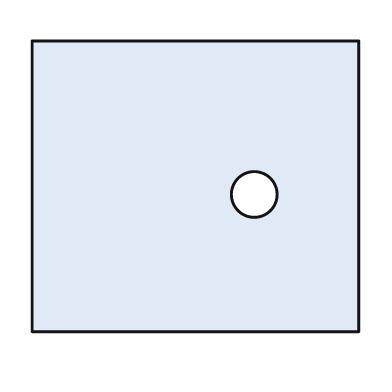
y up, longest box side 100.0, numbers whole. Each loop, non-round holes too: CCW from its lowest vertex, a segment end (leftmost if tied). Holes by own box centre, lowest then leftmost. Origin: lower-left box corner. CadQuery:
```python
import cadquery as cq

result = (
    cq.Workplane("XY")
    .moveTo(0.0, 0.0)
    .lineTo(100.0, 0.0)
    .lineTo(100.0, 89.0)
    .lineTo(0.0, 89.0)
    .close()
    .moveTo(68.0, 42.0)
    .circle(7.0)
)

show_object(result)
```